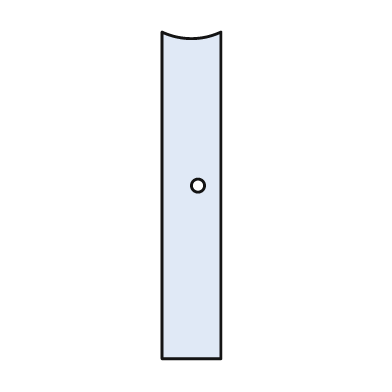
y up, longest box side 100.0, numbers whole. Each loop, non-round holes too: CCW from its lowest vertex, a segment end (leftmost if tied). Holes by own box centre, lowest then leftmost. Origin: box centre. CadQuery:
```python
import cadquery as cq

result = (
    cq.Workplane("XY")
    .moveTo(-9.0, -50.0)
    .lineTo(9.0, -50.0)
    .lineTo(9.0, 50.0)
    .threePointArc((0.0, 48.0), (-9.0, 50.0))
    .close()
    .moveTo(2.0, 3.0)
    .circle(2.0)
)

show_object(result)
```